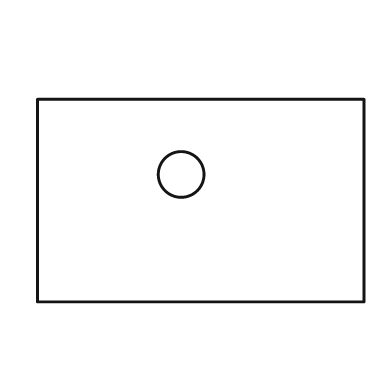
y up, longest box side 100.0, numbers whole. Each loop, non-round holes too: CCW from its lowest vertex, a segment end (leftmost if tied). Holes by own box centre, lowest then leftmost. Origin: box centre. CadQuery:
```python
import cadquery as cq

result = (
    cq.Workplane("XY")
    .moveTo(-50.0, -31.0)
    .lineTo(50.0, -31.0)
    .lineTo(50.0, 31.0)
    .lineTo(-50.0, 31.0)
    .close()
    .moveTo(-6.0, 8.0)
    .circle(7.0)
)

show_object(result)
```